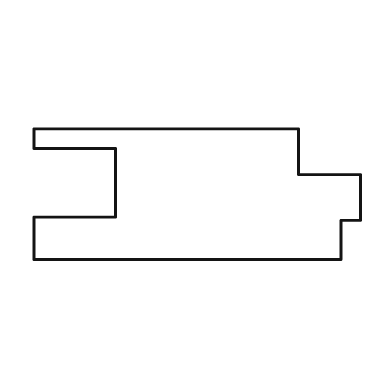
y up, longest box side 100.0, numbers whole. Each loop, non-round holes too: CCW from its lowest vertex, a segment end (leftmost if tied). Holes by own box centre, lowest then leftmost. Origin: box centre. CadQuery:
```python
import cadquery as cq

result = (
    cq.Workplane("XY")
    .moveTo(-50.0, -20.0)
    .lineTo(44.0, -20.0)
    .lineTo(44.0, -8.0)
    .lineTo(50.0, -8.0)
    .lineTo(50.0, 6.0)
    .lineTo(31.0, 6.0)
    .lineTo(31.0, 20.0)
    .lineTo(-50.0, 20.0)
    .lineTo(-50.0, 14.0)
    .lineTo(-25.0, 14.0)
    .lineTo(-25.0, -7.0)
    .lineTo(-50.0, -7.0)
    .close()
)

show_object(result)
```